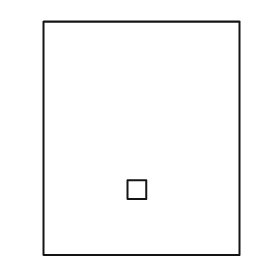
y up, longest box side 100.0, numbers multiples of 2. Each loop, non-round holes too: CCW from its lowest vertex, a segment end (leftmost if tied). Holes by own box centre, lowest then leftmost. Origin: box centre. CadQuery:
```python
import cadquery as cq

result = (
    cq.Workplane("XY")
    .moveTo(-42.0, -50.0)
    .lineTo(42.0, -50.0)
    .lineTo(42.0, 50.0)
    .lineTo(-42.0, 50.0)
    .close()
    .moveTo(-6.0, -26.0)
    .lineTo(2.0, -26.0)
    .lineTo(2.0, -18.0)
    .lineTo(-6.0, -18.0)
    .close()
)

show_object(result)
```